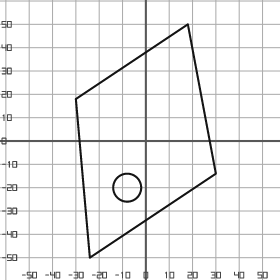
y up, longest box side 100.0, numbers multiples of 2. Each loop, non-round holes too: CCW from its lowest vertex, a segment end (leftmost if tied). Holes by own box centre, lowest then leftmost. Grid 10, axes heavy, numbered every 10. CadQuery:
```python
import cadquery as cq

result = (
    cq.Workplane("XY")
    .moveTo(-24.0, -50.0)
    .lineTo(30.0, -14.0)
    .lineTo(18.0, 50.0)
    .lineTo(-30.0, 18.0)
    .close()
    .moveTo(-8.0, -20.0)
    .circle(6.0)
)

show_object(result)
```